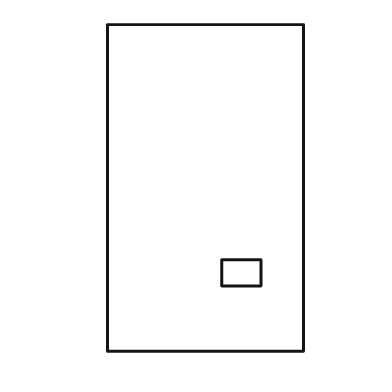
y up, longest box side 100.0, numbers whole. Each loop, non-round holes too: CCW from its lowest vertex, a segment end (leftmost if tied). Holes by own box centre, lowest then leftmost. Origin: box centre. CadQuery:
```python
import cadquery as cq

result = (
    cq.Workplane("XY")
    .moveTo(-30.0, -50.0)
    .lineTo(30.0, -50.0)
    .lineTo(30.0, 50.0)
    .lineTo(-30.0, 50.0)
    .close()
    .moveTo(5.0, -30.0)
    .lineTo(17.0, -30.0)
    .lineTo(17.0, -22.0)
    .lineTo(5.0, -22.0)
    .close()
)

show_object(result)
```